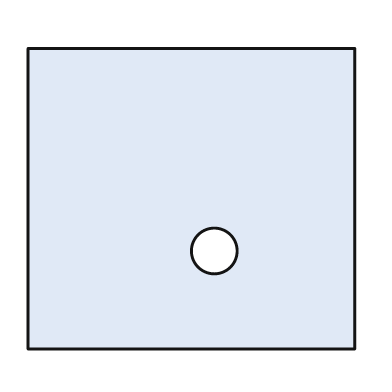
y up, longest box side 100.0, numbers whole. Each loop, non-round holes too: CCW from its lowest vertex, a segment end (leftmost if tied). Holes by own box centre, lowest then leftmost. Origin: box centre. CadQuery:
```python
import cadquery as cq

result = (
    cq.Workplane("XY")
    .moveTo(-50.0, -46.0)
    .lineTo(50.0, -46.0)
    .lineTo(50.0, 46.0)
    .lineTo(-50.0, 46.0)
    .close()
    .moveTo(7.0, -16.0)
    .circle(7.0)
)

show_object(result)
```